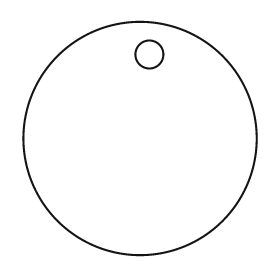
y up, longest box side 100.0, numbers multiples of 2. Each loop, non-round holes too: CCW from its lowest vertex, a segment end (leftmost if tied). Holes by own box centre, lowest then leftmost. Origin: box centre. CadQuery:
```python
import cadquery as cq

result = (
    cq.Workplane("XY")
    .moveTo(0.0, 0.0)
    .circle(50.0)
    .moveTo(4.0, 36.0)
    .circle(6.0)
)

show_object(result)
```